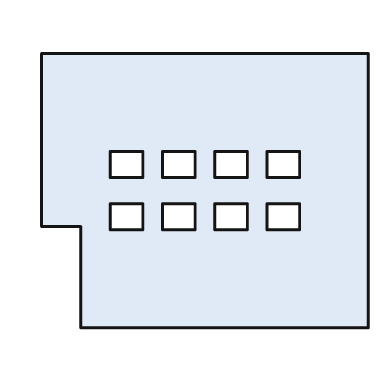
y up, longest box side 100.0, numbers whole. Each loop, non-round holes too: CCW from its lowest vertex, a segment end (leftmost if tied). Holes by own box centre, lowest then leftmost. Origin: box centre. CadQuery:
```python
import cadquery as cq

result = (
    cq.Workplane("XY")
    .moveTo(-38.0, -42.0)
    .lineTo(50.0, -42.0)
    .lineTo(50.0, 42.0)
    .lineTo(-50.0, 42.0)
    .lineTo(-50.0, -11.0)
    .lineTo(-38.0, -11.0)
    .close()
    .moveTo(-29.0, -12.0)
    .lineTo(-19.0, -12.0)
    .lineTo(-19.0, -4.0)
    .lineTo(-29.0, -4.0)
    .close()
    .moveTo(-13.0, -12.0)
    .lineTo(-3.0, -12.0)
    .lineTo(-3.0, -4.0)
    .lineTo(-13.0, -4.0)
    .close()
    .moveTo(3.0, -12.0)
    .lineTo(13.0, -12.0)
    .lineTo(13.0, -4.0)
    .lineTo(3.0, -4.0)
    .close()
    .moveTo(19.0, -12.0)
    .lineTo(29.0, -12.0)
    .lineTo(29.0, -4.0)
    .lineTo(19.0, -4.0)
    .close()
    .moveTo(-29.0, 4.0)
    .lineTo(-19.0, 4.0)
    .lineTo(-19.0, 12.0)
    .lineTo(-29.0, 12.0)
    .close()
    .moveTo(-13.0, 4.0)
    .lineTo(-3.0, 4.0)
    .lineTo(-3.0, 12.0)
    .lineTo(-13.0, 12.0)
    .close()
    .moveTo(3.0, 4.0)
    .lineTo(13.0, 4.0)
    .lineTo(13.0, 12.0)
    .lineTo(3.0, 12.0)
    .close()
    .moveTo(19.0, 4.0)
    .lineTo(29.0, 4.0)
    .lineTo(29.0, 12.0)
    .lineTo(19.0, 12.0)
    .close()
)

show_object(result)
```